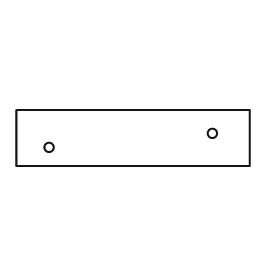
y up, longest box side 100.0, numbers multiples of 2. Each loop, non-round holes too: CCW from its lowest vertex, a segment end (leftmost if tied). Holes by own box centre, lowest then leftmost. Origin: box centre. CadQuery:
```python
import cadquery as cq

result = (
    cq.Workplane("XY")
    .moveTo(-50.0, -12.0)
    .lineTo(50.0, -12.0)
    .lineTo(50.0, 12.0)
    .lineTo(-50.0, 12.0)
    .close()
    .moveTo(-36.0, -4.0)
    .circle(2.0)
    .moveTo(34.0, 2.0)
    .circle(2.0)
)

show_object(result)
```